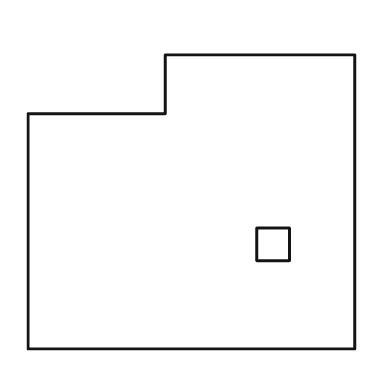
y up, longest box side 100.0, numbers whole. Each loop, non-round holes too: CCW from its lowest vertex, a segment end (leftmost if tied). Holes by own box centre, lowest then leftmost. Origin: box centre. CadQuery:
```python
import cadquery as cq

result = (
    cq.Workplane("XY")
    .moveTo(-50.0, -45.0)
    .lineTo(50.0, -45.0)
    .lineTo(50.0, 45.0)
    .lineTo(-8.0, 45.0)
    .lineTo(-8.0, 27.0)
    .lineTo(-50.0, 27.0)
    .close()
    .moveTo(20.0, -18.0)
    .lineTo(30.0, -18.0)
    .lineTo(30.0, -8.0)
    .lineTo(20.0, -8.0)
    .close()
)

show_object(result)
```